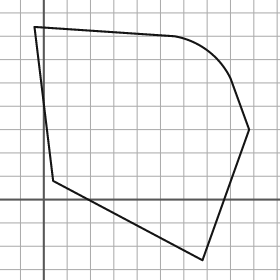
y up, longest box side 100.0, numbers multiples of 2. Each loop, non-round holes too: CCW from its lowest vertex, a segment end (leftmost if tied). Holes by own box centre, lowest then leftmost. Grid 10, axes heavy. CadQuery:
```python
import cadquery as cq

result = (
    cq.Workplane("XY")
    .moveTo(68.0, -26.0)
    .lineTo(88.0, 30.0)
    .lineTo(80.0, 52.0)
    .threePointArc((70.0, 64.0), (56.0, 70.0))
    .lineTo(-4.0, 74.0)
    .lineTo(4.0, 8.0)
    .close()
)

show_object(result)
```